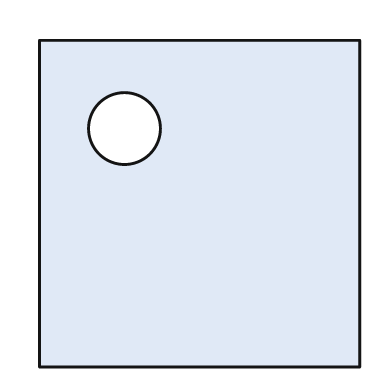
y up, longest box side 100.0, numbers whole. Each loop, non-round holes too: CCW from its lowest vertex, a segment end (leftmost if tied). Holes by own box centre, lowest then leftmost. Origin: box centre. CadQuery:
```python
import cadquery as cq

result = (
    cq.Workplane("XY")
    .moveTo(-49.0, -50.0)
    .lineTo(49.0, -50.0)
    .lineTo(49.0, 50.0)
    .lineTo(-49.0, 50.0)
    .close()
    .moveTo(-23.0, 23.0)
    .circle(11.0)
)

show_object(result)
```